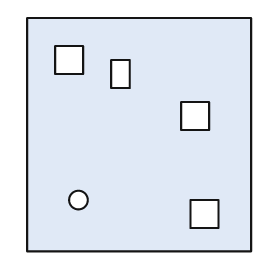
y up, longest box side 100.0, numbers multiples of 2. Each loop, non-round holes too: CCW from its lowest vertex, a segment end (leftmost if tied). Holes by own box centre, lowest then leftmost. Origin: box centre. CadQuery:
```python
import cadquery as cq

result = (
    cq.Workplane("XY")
    .moveTo(-48.0, -50.0)
    .lineTo(48.0, -50.0)
    .lineTo(48.0, 50.0)
    .lineTo(-48.0, 50.0)
    .close()
    .moveTo(22.0, -40.0)
    .lineTo(34.0, -40.0)
    .lineTo(34.0, -28.0)
    .lineTo(22.0, -28.0)
    .close()
    .moveTo(-26.0, -28.0)
    .circle(4.0)
    .moveTo(18.0, 2.0)
    .lineTo(30.0, 2.0)
    .lineTo(30.0, 14.0)
    .lineTo(18.0, 14.0)
    .close()
    .moveTo(-12.0, 20.0)
    .lineTo(-4.0, 20.0)
    .lineTo(-4.0, 32.0)
    .lineTo(-12.0, 32.0)
    .close()
    .moveTo(-36.0, 26.0)
    .lineTo(-24.0, 26.0)
    .lineTo(-24.0, 38.0)
    .lineTo(-36.0, 38.0)
    .close()
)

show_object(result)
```